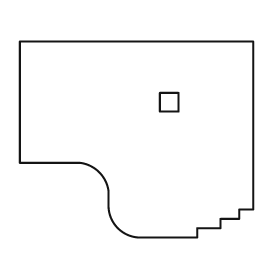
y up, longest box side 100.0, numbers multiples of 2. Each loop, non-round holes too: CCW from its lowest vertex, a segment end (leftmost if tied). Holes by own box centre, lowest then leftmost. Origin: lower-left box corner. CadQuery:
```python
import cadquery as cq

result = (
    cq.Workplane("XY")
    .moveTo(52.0, 0.0)
    .lineTo(76.0, 0.0)
    .lineTo(76.0, 4.0)
    .lineTo(86.0, 4.0)
    .lineTo(86.0, 8.0)
    .lineTo(94.0, 8.0)
    .lineTo(94.0, 12.0)
    .lineTo(100.0, 12.0)
    .lineTo(100.0, 84.0)
    .lineTo(0.0, 84.0)
    .lineTo(0.0, 32.0)
    .lineTo(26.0, 32.0)
    .threePointArc((34.0, 28.0), (38.0, 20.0))
    .lineTo(38.0, 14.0)
    .threePointArc((42.0, 4.0), (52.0, 0.0))
    .close()
    .moveTo(60.0, 54.0)
    .lineTo(68.0, 54.0)
    .lineTo(68.0, 62.0)
    .lineTo(60.0, 62.0)
    .close()
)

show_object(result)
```